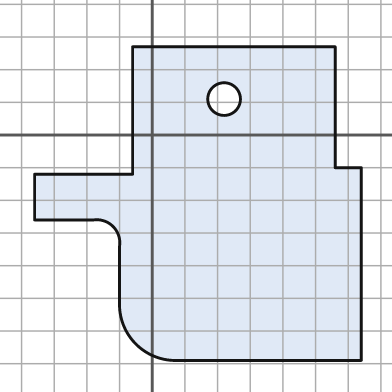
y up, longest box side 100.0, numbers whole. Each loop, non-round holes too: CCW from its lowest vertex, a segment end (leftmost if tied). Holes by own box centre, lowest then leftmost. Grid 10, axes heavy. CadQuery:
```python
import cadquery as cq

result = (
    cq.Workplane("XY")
    .moveTo(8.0, -69.0)
    .lineTo(64.0, -69.0)
    .lineTo(64.0, -10.0)
    .lineTo(56.0, -10.0)
    .lineTo(56.0, 27.0)
    .lineTo(-6.0, 27.0)
    .lineTo(-6.0, -12.0)
    .lineTo(-36.0, -12.0)
    .lineTo(-36.0, -26.0)
    .lineTo(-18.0, -26.0)
    .threePointArc((-12.0, -28.0), (-10.0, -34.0))
    .lineTo(-10.0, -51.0)
    .threePointArc((-5.0, -64.0), (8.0, -69.0))
    .close()
    .moveTo(22.0, 11.0)
    .circle(5.0)
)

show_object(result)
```